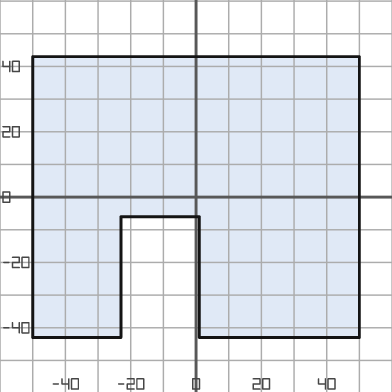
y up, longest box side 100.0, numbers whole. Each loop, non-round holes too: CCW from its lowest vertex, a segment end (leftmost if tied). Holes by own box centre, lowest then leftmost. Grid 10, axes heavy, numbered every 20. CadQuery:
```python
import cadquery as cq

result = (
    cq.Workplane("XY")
    .moveTo(-50.0, -43.0)
    .lineTo(-23.0, -43.0)
    .lineTo(-23.0, -6.0)
    .lineTo(1.0, -6.0)
    .lineTo(1.0, -43.0)
    .lineTo(50.0, -43.0)
    .lineTo(50.0, 43.0)
    .lineTo(-50.0, 43.0)
    .close()
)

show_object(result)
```